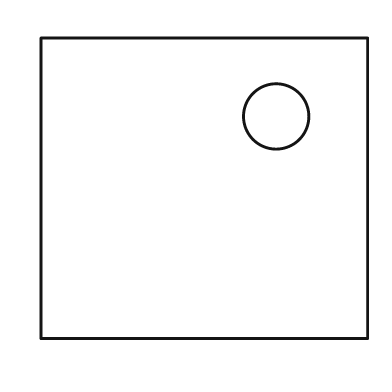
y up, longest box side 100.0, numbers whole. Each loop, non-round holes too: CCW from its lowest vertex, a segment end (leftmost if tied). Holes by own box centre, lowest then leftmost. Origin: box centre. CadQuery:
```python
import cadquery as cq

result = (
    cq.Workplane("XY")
    .moveTo(-50.0, -46.0)
    .lineTo(50.0, -46.0)
    .lineTo(50.0, 46.0)
    .lineTo(-50.0, 46.0)
    .close()
    .moveTo(22.0, 22.0)
    .circle(10.0)
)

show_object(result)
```